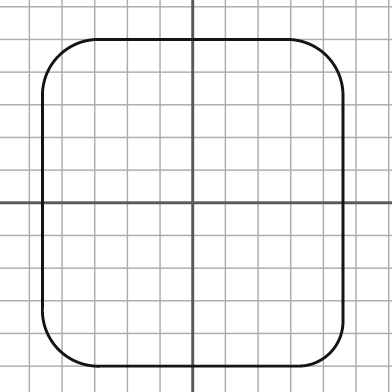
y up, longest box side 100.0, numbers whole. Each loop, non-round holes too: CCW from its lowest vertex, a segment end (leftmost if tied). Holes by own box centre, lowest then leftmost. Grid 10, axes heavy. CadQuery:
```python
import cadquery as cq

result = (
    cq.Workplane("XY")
    .moveTo(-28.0, -50.0)
    .lineTo(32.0, -50.0)
    .threePointArc((42.0, -46.0), (46.0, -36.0))
    .lineTo(46.0, 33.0)
    .threePointArc((41.0, 45.0), (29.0, 50.0))
    .lineTo(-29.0, 50.0)
    .threePointArc((-41.0, 45.0), (-46.0, 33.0))
    .lineTo(-46.0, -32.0)
    .threePointArc((-41.0, -45.0), (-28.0, -50.0))
    .close()
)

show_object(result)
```